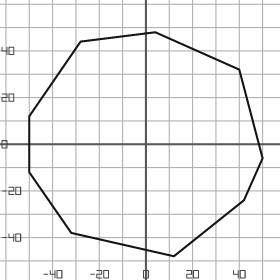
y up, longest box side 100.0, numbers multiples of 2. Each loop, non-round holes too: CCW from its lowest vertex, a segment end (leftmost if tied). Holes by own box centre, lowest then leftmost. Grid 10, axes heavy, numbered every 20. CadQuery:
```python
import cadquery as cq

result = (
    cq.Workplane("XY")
    .moveTo(12.0, -48.0)
    .lineTo(42.0, -24.0)
    .lineTo(50.0, -6.0)
    .lineTo(40.0, 32.0)
    .lineTo(4.0, 48.0)
    .lineTo(-28.0, 44.0)
    .lineTo(-50.0, 12.0)
    .lineTo(-50.0, -12.0)
    .lineTo(-32.0, -38.0)
    .close()
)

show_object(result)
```